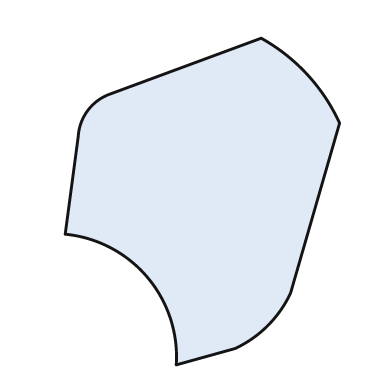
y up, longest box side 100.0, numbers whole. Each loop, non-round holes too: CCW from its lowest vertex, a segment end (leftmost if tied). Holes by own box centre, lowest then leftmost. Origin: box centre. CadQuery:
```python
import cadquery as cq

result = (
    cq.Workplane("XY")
    .moveTo(-8.0, -50.0)
    .lineTo(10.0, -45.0)
    .threePointArc((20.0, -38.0), (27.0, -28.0))
    .lineTo(42.0, 24.0)
    .threePointArc((32.0, 39.0), (18.0, 50.0))
    .lineTo(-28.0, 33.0)
    .threePointArc((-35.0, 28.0), (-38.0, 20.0))
    .lineTo(-42.0, -10.0)
    .threePointArc((-17.0, -23.0), (-8.0, -50.0))
    .close()
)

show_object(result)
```